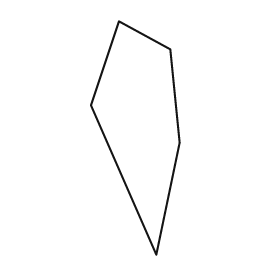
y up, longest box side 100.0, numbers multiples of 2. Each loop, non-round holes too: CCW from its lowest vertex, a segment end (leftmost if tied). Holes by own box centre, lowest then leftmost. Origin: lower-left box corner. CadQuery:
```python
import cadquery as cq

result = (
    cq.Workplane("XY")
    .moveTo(28.0, 0.0)
    .lineTo(38.0, 48.0)
    .lineTo(34.0, 88.0)
    .lineTo(12.0, 100.0)
    .lineTo(0.0, 64.0)
    .close()
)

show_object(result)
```